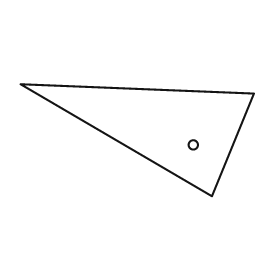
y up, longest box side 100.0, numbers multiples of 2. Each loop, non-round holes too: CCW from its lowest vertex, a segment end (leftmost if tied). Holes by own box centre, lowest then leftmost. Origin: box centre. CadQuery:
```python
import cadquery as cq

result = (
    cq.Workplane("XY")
    .moveTo(32.0, -24.0)
    .lineTo(50.0, 20.0)
    .lineTo(-50.0, 24.0)
    .close()
    .moveTo(24.0, -2.0)
    .circle(2.0)
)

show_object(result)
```